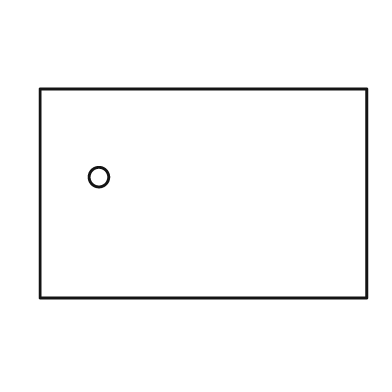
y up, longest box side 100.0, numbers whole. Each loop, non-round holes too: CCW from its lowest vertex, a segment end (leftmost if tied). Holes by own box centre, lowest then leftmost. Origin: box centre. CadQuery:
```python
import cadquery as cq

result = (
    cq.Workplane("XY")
    .moveTo(-50.0, -32.0)
    .lineTo(50.0, -32.0)
    .lineTo(50.0, 32.0)
    .lineTo(-50.0, 32.0)
    .close()
    .moveTo(-32.0, 5.0)
    .circle(3.0)
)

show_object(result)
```